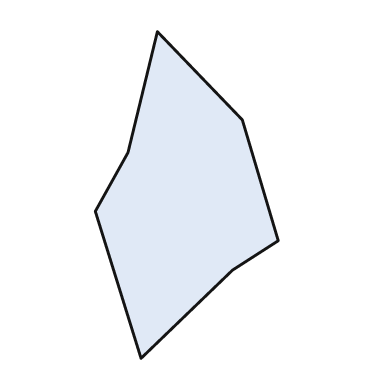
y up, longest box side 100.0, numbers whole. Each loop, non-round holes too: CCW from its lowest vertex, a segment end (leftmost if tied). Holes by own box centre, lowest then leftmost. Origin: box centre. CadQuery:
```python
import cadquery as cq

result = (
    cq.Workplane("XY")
    .moveTo(-14.0, -50.0)
    .lineTo(14.0, -23.0)
    .lineTo(28.0, -14.0)
    .lineTo(17.0, 23.0)
    .lineTo(-9.0, 50.0)
    .lineTo(-18.0, 13.0)
    .lineTo(-28.0, -5.0)
    .close()
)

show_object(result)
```